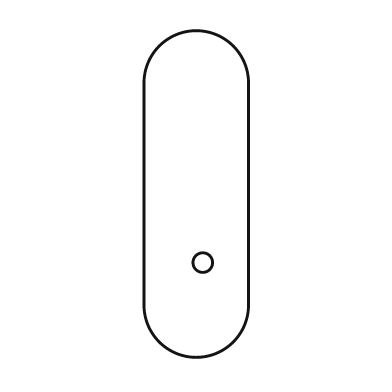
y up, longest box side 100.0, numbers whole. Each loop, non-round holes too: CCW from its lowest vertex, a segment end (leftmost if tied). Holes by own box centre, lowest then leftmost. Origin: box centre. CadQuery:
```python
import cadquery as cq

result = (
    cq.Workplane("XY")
    .moveTo(-16.0, -34.0)
    .threePointArc((0.0, -50.0), (16.0, -34.0))
    .lineTo(16.0, 34.0)
    .threePointArc((0.0, 50.0), (-16.0, 34.0))
    .close()
    .moveTo(2.0, -21.0)
    .circle(3.0)
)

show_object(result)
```